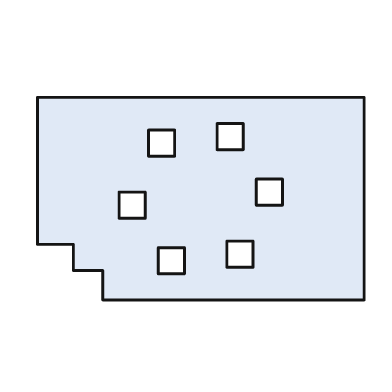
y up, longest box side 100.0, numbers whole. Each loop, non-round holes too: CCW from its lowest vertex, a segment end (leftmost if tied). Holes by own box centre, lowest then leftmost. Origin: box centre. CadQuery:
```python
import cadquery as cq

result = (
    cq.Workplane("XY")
    .moveTo(-30.0, -31.0)
    .lineTo(50.0, -31.0)
    .lineTo(50.0, 31.0)
    .lineTo(-50.0, 31.0)
    .lineTo(-50.0, -14.0)
    .lineTo(-39.0, -14.0)
    .lineTo(-39.0, -22.0)
    .lineTo(-30.0, -22.0)
    .close()
    .moveTo(-13.0, -23.0)
    .lineTo(-5.0, -23.0)
    .lineTo(-5.0, -15.0)
    .lineTo(-13.0, -15.0)
    .close()
    .moveTo(8.0, -21.0)
    .lineTo(16.0, -21.0)
    .lineTo(16.0, -13.0)
    .lineTo(8.0, -13.0)
    .close()
    .moveTo(-25.0, -6.0)
    .lineTo(-17.0, -6.0)
    .lineTo(-17.0, 2.0)
    .lineTo(-25.0, 2.0)
    .close()
    .moveTo(17.0, -2.0)
    .lineTo(25.0, -2.0)
    .lineTo(25.0, 6.0)
    .lineTo(17.0, 6.0)
    .close()
    .moveTo(-16.0, 13.0)
    .lineTo(-8.0, 13.0)
    .lineTo(-8.0, 21.0)
    .lineTo(-16.0, 21.0)
    .close()
    .moveTo(5.0, 15.0)
    .lineTo(13.0, 15.0)
    .lineTo(13.0, 23.0)
    .lineTo(5.0, 23.0)
    .close()
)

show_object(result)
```